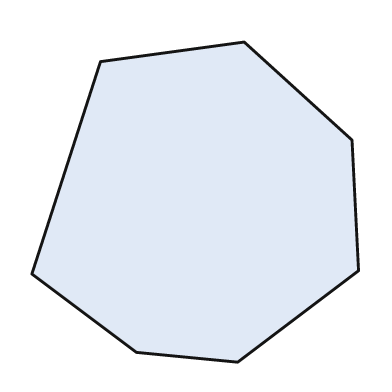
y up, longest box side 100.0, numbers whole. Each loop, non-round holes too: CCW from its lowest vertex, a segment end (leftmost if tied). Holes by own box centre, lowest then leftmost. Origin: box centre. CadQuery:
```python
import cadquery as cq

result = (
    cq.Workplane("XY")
    .moveTo(13.0, -49.0)
    .lineTo(50.0, -21.0)
    .lineTo(48.0, 19.0)
    .lineTo(15.0, 49.0)
    .lineTo(-29.0, 43.0)
    .lineTo(-50.0, -22.0)
    .lineTo(-18.0, -46.0)
    .close()
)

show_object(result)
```